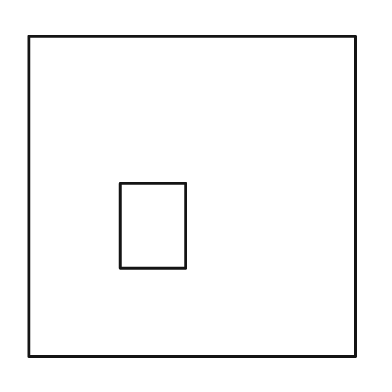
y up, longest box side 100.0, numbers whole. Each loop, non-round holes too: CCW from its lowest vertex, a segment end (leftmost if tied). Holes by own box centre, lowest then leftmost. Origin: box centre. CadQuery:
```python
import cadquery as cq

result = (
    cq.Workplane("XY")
    .moveTo(-50.0, -49.0)
    .lineTo(50.0, -49.0)
    .lineTo(50.0, 49.0)
    .lineTo(-50.0, 49.0)
    .close()
    .moveTo(-22.0, -22.0)
    .lineTo(-2.0, -22.0)
    .lineTo(-2.0, 4.0)
    .lineTo(-22.0, 4.0)
    .close()
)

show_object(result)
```